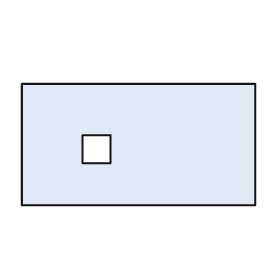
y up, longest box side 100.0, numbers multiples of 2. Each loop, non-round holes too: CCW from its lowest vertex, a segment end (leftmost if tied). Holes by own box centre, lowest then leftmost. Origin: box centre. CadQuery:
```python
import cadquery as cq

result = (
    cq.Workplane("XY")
    .moveTo(-50.0, -26.0)
    .lineTo(50.0, -26.0)
    .lineTo(50.0, 26.0)
    .lineTo(-50.0, 26.0)
    .close()
    .moveTo(-24.0, -8.0)
    .lineTo(-12.0, -8.0)
    .lineTo(-12.0, 4.0)
    .lineTo(-24.0, 4.0)
    .close()
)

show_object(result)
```